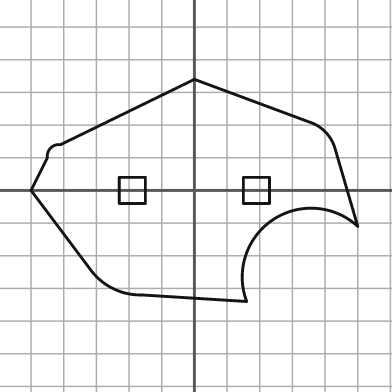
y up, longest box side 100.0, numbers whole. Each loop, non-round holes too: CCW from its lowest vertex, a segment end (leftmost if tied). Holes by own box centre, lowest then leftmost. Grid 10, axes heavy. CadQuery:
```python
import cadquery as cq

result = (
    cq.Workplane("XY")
    .moveTo(16.0, -34.0)
    .threePointArc((24.0, -9.0), (50.0, -11.0))
    .lineTo(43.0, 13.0)
    .threePointArc((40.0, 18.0), (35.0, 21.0))
    .lineTo(0.0, 34.0)
    .lineTo(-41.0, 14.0)
    .threePointArc((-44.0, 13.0), (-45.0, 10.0))
    .lineTo(-50.0, 0.0)
    .lineTo(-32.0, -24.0)
    .threePointArc((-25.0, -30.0), (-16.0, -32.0))
    .close()
    .moveTo(-23.0, -4.0)
    .lineTo(-15.0, -4.0)
    .lineTo(-15.0, 4.0)
    .lineTo(-23.0, 4.0)
    .close()
    .moveTo(15.0, -4.0)
    .lineTo(23.0, -4.0)
    .lineTo(23.0, 4.0)
    .lineTo(15.0, 4.0)
    .close()
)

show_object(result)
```